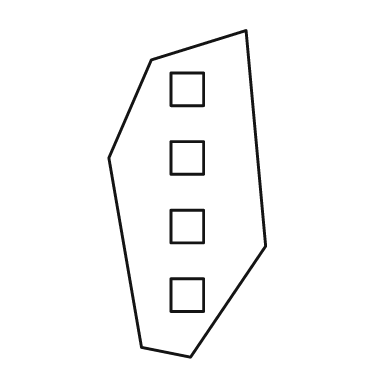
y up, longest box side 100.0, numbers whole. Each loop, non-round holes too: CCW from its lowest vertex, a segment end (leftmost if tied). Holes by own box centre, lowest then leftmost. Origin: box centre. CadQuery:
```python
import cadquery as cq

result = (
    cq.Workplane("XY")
    .moveTo(1.0, -50.0)
    .lineTo(24.0, -16.0)
    .lineTo(18.0, 50.0)
    .lineTo(-11.0, 41.0)
    .lineTo(-24.0, 11.0)
    .lineTo(-14.0, -47.0)
    .close()
    .moveTo(-5.0, -36.0)
    .lineTo(5.0, -36.0)
    .lineTo(5.0, -26.0)
    .lineTo(-5.0, -26.0)
    .close()
    .moveTo(-5.0, -15.0)
    .lineTo(5.0, -15.0)
    .lineTo(5.0, -5.0)
    .lineTo(-5.0, -5.0)
    .close()
    .moveTo(-5.0, 6.0)
    .lineTo(5.0, 6.0)
    .lineTo(5.0, 16.0)
    .lineTo(-5.0, 16.0)
    .close()
    .moveTo(-5.0, 27.0)
    .lineTo(5.0, 27.0)
    .lineTo(5.0, 37.0)
    .lineTo(-5.0, 37.0)
    .close()
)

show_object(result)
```